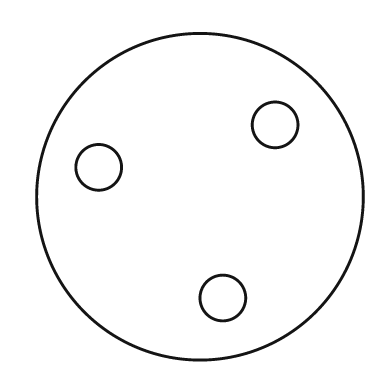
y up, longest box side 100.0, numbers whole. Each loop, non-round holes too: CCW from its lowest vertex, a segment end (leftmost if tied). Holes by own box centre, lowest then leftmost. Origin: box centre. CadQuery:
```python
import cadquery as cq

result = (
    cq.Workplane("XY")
    .moveTo(0.0, 0.0)
    .circle(50.0)
    .moveTo(7.0, -31.0)
    .circle(7.0)
    .moveTo(-31.0, 9.0)
    .circle(7.0)
    .moveTo(23.0, 22.0)
    .circle(7.0)
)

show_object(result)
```